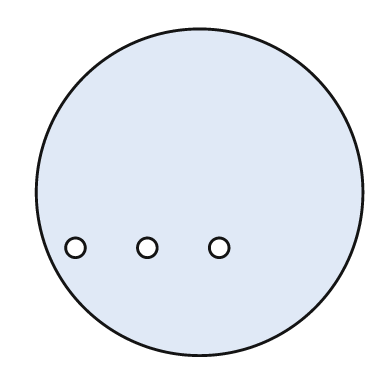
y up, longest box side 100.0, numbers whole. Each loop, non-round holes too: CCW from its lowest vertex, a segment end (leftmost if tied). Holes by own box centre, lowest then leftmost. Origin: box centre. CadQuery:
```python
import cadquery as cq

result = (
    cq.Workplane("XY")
    .moveTo(0.0, 0.0)
    .circle(50.0)
    .moveTo(-38.0, -17.0)
    .circle(3.0)
    .moveTo(-16.0, -17.0)
    .circle(3.0)
    .moveTo(6.0, -17.0)
    .circle(3.0)
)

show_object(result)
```